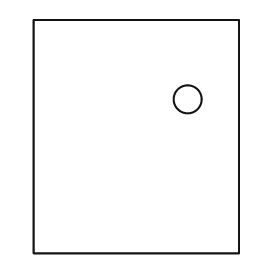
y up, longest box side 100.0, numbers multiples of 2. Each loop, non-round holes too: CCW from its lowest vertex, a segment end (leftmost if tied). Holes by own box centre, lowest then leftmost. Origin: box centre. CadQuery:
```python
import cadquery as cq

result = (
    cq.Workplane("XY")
    .moveTo(-44.0, -50.0)
    .lineTo(44.0, -50.0)
    .lineTo(44.0, 50.0)
    .lineTo(-44.0, 50.0)
    .close()
    .moveTo(22.0, 16.0)
    .circle(6.0)
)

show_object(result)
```